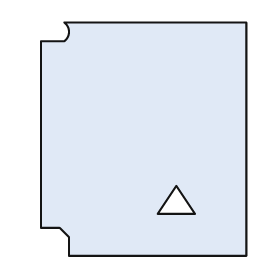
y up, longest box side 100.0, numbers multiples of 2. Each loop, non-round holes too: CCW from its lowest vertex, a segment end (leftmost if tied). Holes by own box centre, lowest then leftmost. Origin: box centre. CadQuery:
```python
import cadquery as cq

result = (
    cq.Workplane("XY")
    .moveTo(-32.0, -50.0)
    .lineTo(44.0, -50.0)
    .lineTo(44.0, 50.0)
    .lineTo(-34.0, 50.0)
    .threePointArc((-32.0, 46.0), (-34.0, 42.0))
    .lineTo(-44.0, 42.0)
    .lineTo(-44.0, -38.0)
    .lineTo(-36.0, -38.0)
    .lineTo(-32.0, -42.0)
    .close()
    .moveTo(6.0, -32.0)
    .lineTo(22.0, -32.0)
    .lineTo(14.0, -20.0)
    .close()
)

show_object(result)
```